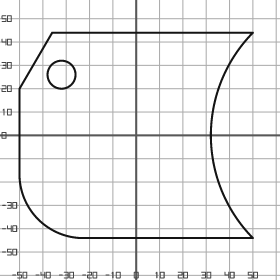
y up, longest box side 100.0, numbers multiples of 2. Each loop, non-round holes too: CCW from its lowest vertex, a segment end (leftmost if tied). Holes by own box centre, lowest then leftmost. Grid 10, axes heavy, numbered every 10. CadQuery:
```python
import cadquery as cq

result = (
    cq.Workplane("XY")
    .moveTo(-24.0, -44.0)
    .lineTo(50.0, -44.0)
    .threePointArc((32.0, 0.0), (50.0, 44.0))
    .lineTo(-36.0, 44.0)
    .lineTo(-50.0, 20.0)
    .lineTo(-50.0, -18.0)
    .threePointArc((-42.0, -36.0), (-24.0, -44.0))
    .close()
    .moveTo(-32.0, 26.0)
    .circle(6.0)
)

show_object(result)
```